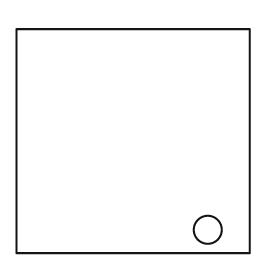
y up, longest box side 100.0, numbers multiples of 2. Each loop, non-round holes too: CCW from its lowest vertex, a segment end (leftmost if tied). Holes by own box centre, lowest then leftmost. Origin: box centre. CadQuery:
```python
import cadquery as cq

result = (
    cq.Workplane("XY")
    .moveTo(-50.0, -48.0)
    .lineTo(50.0, -48.0)
    .lineTo(50.0, 48.0)
    .lineTo(-50.0, 48.0)
    .close()
    .moveTo(32.0, -38.0)
    .circle(6.0)
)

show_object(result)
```